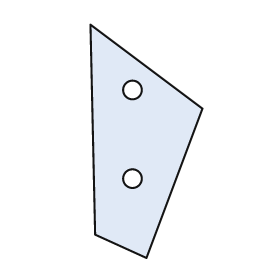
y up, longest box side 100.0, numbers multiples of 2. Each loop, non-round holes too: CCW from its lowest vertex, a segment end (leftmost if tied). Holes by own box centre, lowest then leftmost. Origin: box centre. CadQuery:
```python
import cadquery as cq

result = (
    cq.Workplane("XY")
    .moveTo(0.0, -50.0)
    .lineTo(24.0, 14.0)
    .lineTo(-24.0, 50.0)
    .lineTo(-22.0, -40.0)
    .close()
    .moveTo(-6.0, -16.0)
    .circle(4.0)
    .moveTo(-6.0, 22.0)
    .circle(4.0)
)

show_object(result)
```